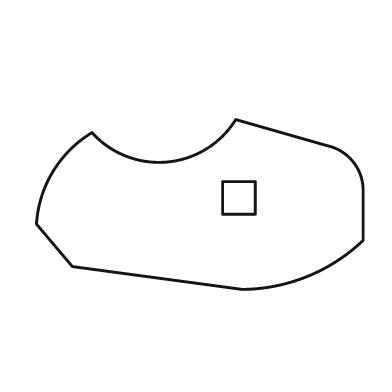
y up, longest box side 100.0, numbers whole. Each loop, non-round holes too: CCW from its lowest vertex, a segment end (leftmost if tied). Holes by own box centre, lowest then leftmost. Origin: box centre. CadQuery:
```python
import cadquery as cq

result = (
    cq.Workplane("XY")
    .moveTo(13.0, -26.0)
    .threePointArc((33.0, -22.0), (50.0, -11.0))
    .lineTo(50.0, 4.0)
    .threePointArc((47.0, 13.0), (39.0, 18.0))
    .lineTo(11.0, 26.0)
    .threePointArc((-10.0, 13.0), (-33.0, 22.0))
    .threePointArc((-45.0, 10.0), (-50.0, -6.0))
    .lineTo(-39.0, -19.0)
    .close()
    .moveTo(7.0, -3.0)
    .lineTo(17.0, -3.0)
    .lineTo(17.0, 7.0)
    .lineTo(7.0, 7.0)
    .close()
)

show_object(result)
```